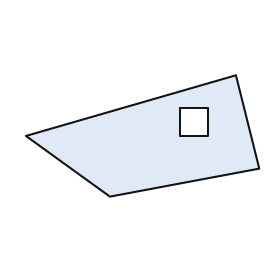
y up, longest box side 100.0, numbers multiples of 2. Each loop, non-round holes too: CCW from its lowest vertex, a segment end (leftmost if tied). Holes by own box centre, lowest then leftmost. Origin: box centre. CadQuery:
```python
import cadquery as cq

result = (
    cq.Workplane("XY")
    .moveTo(-14.0, -26.0)
    .lineTo(50.0, -14.0)
    .lineTo(40.0, 26.0)
    .lineTo(-50.0, 0.0)
    .close()
    .moveTo(16.0, 0.0)
    .lineTo(28.0, 0.0)
    .lineTo(28.0, 12.0)
    .lineTo(16.0, 12.0)
    .close()
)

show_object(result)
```